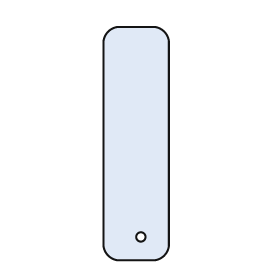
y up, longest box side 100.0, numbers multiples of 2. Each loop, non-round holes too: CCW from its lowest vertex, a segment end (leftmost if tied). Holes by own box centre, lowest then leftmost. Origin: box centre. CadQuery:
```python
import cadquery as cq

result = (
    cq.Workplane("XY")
    .moveTo(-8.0, -50.0)
    .lineTo(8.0, -50.0)
    .threePointArc((12.0, -48.0), (14.0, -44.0))
    .lineTo(14.0, 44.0)
    .threePointArc((12.0, 48.0), (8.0, 50.0))
    .lineTo(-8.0, 50.0)
    .threePointArc((-12.0, 48.0), (-14.0, 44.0))
    .lineTo(-14.0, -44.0)
    .threePointArc((-12.0, -48.0), (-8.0, -50.0))
    .close()
    .moveTo(2.0, -40.0)
    .circle(2.0)
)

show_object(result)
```